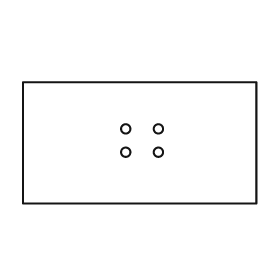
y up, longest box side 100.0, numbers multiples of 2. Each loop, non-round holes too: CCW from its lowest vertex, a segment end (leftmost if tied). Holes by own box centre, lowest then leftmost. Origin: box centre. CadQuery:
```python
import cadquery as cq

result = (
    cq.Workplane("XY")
    .moveTo(-50.0, -26.0)
    .lineTo(50.0, -26.0)
    .lineTo(50.0, 26.0)
    .lineTo(-50.0, 26.0)
    .close()
    .moveTo(-6.0, -4.0)
    .circle(2.0)
    .moveTo(8.0, -4.0)
    .circle(2.0)
    .moveTo(-6.0, 6.0)
    .circle(2.0)
    .moveTo(8.0, 6.0)
    .circle(2.0)
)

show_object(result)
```